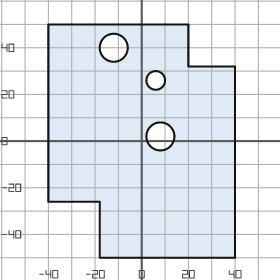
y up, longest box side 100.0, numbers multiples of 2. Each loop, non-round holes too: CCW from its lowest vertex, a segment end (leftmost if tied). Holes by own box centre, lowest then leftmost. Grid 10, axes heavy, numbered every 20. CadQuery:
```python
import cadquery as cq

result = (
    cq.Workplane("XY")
    .moveTo(-18.0, -50.0)
    .lineTo(40.0, -50.0)
    .lineTo(40.0, 32.0)
    .lineTo(20.0, 32.0)
    .lineTo(20.0, 50.0)
    .lineTo(-40.0, 50.0)
    .lineTo(-40.0, -26.0)
    .lineTo(-18.0, -26.0)
    .close()
    .moveTo(8.0, 2.0)
    .circle(6.0)
    .moveTo(6.0, 26.0)
    .circle(4.0)
    .moveTo(-12.0, 40.0)
    .circle(6.0)
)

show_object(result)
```